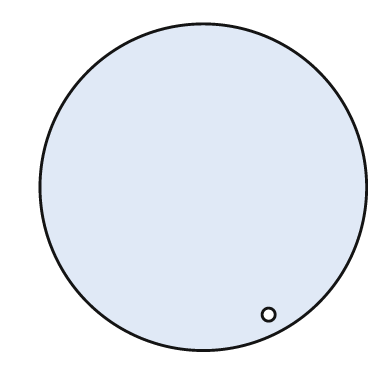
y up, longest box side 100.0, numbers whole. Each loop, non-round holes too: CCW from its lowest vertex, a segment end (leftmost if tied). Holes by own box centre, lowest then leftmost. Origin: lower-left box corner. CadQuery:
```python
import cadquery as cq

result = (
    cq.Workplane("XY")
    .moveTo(50.0, 50.0)
    .circle(50.0)
    .moveTo(70.0, 11.0)
    .circle(2.0)
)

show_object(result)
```